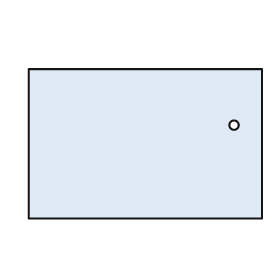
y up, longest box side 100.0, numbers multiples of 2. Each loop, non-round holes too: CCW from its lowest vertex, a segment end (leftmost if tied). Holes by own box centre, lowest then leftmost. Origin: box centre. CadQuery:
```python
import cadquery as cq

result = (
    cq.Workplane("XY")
    .moveTo(-50.0, -32.0)
    .lineTo(50.0, -32.0)
    .lineTo(50.0, 32.0)
    .lineTo(-50.0, 32.0)
    .close()
    .moveTo(38.0, 8.0)
    .circle(2.0)
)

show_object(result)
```